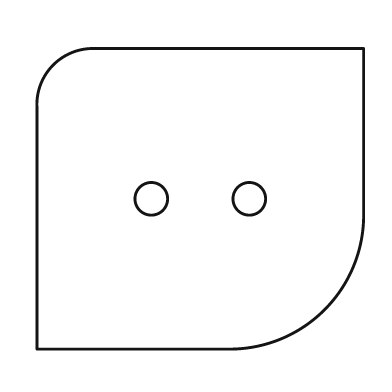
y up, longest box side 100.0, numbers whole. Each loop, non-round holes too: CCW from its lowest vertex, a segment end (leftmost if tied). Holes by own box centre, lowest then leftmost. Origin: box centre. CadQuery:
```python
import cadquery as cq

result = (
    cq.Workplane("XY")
    .moveTo(-50.0, -46.0)
    .lineTo(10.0, -46.0)
    .threePointArc((38.0, -34.0), (50.0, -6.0))
    .lineTo(50.0, 46.0)
    .lineTo(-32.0, 46.0)
    .threePointArc((-45.0, 41.0), (-50.0, 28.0))
    .close()
    .moveTo(-15.0, 0.0)
    .circle(5.0)
    .moveTo(15.0, 0.0)
    .circle(5.0)
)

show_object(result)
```